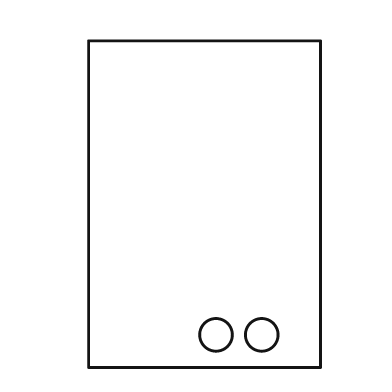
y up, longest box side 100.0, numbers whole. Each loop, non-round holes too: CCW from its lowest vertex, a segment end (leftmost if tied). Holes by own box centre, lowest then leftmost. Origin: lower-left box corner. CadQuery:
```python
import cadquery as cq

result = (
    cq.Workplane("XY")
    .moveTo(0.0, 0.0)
    .lineTo(71.0, 0.0)
    .lineTo(71.0, 100.0)
    .lineTo(0.0, 100.0)
    .close()
    .moveTo(39.0, 10.0)
    .circle(5.0)
    .moveTo(53.0, 10.0)
    .circle(5.0)
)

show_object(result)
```